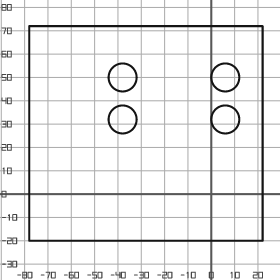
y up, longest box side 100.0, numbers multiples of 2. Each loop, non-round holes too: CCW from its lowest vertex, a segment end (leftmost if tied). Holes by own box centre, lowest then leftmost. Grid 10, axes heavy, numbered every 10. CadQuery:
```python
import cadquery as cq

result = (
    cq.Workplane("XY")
    .moveTo(-78.0, -20.0)
    .lineTo(22.0, -20.0)
    .lineTo(22.0, 72.0)
    .lineTo(-78.0, 72.0)
    .close()
    .moveTo(-38.0, 32.0)
    .circle(6.0)
    .moveTo(6.0, 32.0)
    .circle(6.0)
    .moveTo(-38.0, 50.0)
    .circle(6.0)
    .moveTo(6.0, 50.0)
    .circle(6.0)
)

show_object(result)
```